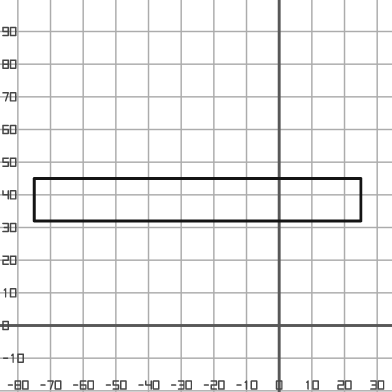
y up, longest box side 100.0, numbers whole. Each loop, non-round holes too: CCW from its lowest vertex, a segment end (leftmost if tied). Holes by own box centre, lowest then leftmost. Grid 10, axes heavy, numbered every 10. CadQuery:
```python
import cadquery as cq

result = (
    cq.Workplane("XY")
    .moveTo(-75.0, 32.0)
    .lineTo(25.0, 32.0)
    .lineTo(25.0, 45.0)
    .lineTo(-75.0, 45.0)
    .close()
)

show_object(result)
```